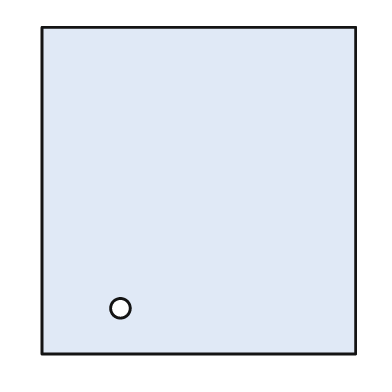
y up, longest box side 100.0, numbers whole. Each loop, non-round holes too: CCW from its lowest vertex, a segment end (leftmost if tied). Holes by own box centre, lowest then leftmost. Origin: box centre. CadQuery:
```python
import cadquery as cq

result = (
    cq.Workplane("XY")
    .moveTo(-48.0, -50.0)
    .lineTo(48.0, -50.0)
    .lineTo(48.0, 50.0)
    .lineTo(-48.0, 50.0)
    .close()
    .moveTo(-24.0, -36.0)
    .circle(3.0)
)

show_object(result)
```